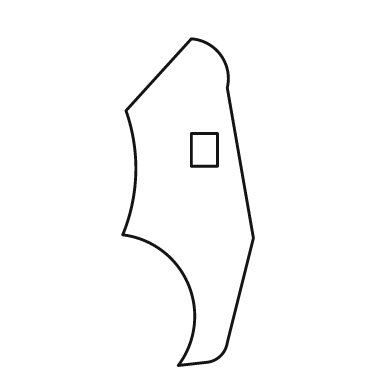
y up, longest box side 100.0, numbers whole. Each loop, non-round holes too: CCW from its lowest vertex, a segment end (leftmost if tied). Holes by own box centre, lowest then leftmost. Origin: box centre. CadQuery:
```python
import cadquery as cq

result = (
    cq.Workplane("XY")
    .moveTo(-3.0, -50.0)
    .lineTo(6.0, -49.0)
    .threePointArc((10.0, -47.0), (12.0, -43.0))
    .lineTo(20.0, -11.0)
    .lineTo(12.0, 35.0)
    .threePointArc((10.0, 45.0), (1.0, 50.0))
    .lineTo(-19.0, 28.0)
    .threePointArc((-16.0, 9.0), (-20.0, -10.0))
    .threePointArc((0.0, -25.0), (-3.0, -50.0))
    .close()
    .moveTo(1.0, 11.0)
    .lineTo(9.0, 11.0)
    .lineTo(9.0, 21.0)
    .lineTo(1.0, 21.0)
    .close()
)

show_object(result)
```